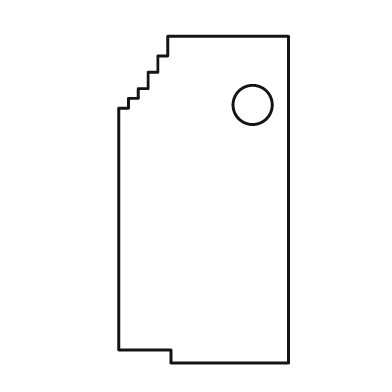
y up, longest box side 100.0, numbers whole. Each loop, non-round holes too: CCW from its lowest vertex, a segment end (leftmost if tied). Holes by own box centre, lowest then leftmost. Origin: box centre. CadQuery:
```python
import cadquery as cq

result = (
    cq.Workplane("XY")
    .moveTo(-10.0, -50.0)
    .lineTo(26.0, -50.0)
    .lineTo(26.0, 50.0)
    .lineTo(-11.0, 50.0)
    .lineTo(-11.0, 44.0)
    .lineTo(-14.0, 44.0)
    .lineTo(-14.0, 39.0)
    .lineTo(-17.0, 39.0)
    .lineTo(-17.0, 34.0)
    .lineTo(-20.0, 34.0)
    .lineTo(-20.0, 31.0)
    .lineTo(-23.0, 31.0)
    .lineTo(-23.0, 28.0)
    .lineTo(-26.0, 28.0)
    .lineTo(-26.0, -46.0)
    .lineTo(-10.0, -46.0)
    .close()
    .moveTo(15.0, 29.0)
    .circle(6.0)
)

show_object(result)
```